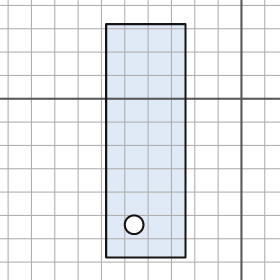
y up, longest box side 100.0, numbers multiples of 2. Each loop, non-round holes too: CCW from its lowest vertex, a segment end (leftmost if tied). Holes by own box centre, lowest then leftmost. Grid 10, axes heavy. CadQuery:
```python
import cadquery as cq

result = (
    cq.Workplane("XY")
    .moveTo(-58.0, -68.0)
    .lineTo(-24.0, -68.0)
    .lineTo(-24.0, 32.0)
    .lineTo(-58.0, 32.0)
    .close()
    .moveTo(-46.0, -54.0)
    .circle(4.0)
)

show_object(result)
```